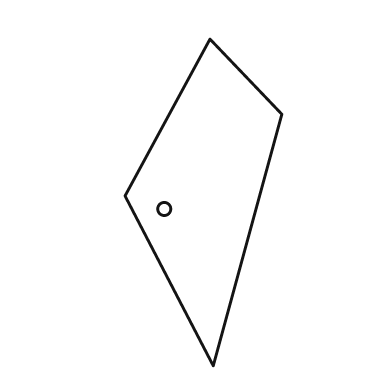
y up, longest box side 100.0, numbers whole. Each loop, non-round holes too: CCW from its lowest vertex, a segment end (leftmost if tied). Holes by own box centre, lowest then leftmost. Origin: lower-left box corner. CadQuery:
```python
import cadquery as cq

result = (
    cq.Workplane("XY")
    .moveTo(27.0, 0.0)
    .lineTo(48.0, 77.0)
    .lineTo(26.0, 100.0)
    .lineTo(0.0, 52.0)
    .close()
    .moveTo(12.0, 48.0)
    .circle(2.0)
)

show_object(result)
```